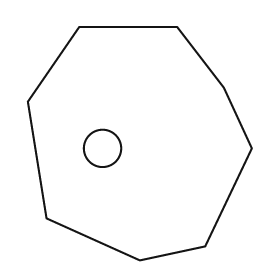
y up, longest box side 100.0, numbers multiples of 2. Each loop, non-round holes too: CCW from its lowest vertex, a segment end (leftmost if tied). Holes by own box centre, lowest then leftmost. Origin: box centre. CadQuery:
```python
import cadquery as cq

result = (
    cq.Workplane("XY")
    .moveTo(0.0, -50.0)
    .lineTo(28.0, -44.0)
    .lineTo(48.0, -2.0)
    .lineTo(36.0, 24.0)
    .lineTo(16.0, 50.0)
    .lineTo(-26.0, 50.0)
    .lineTo(-48.0, 18.0)
    .lineTo(-40.0, -32.0)
    .close()
    .moveTo(-16.0, -2.0)
    .circle(8.0)
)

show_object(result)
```